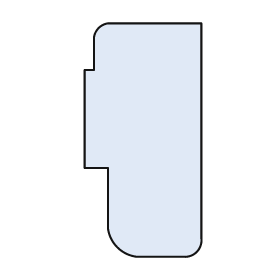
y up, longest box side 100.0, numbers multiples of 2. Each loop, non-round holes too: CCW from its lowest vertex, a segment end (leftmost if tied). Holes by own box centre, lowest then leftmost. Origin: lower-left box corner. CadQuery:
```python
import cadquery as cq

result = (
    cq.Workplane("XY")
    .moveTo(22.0, 0.0)
    .lineTo(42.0, 0.0)
    .threePointArc((48.0, 2.0), (50.0, 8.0))
    .lineTo(50.0, 100.0)
    .lineTo(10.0, 100.0)
    .threePointArc((6.0, 98.0), (4.0, 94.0))
    .lineTo(4.0, 80.0)
    .lineTo(0.0, 80.0)
    .lineTo(0.0, 38.0)
    .lineTo(10.0, 38.0)
    .lineTo(10.0, 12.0)
    .threePointArc((14.0, 4.0), (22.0, 0.0))
    .close()
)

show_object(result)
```